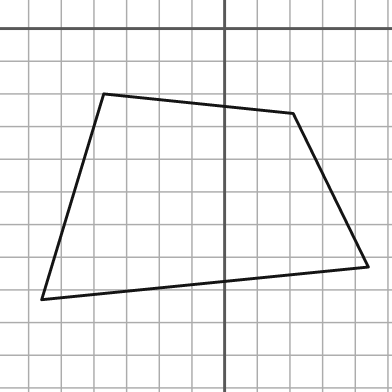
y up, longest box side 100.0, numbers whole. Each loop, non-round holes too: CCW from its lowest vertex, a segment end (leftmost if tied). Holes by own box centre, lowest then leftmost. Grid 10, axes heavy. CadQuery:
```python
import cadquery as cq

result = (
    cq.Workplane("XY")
    .moveTo(-56.0, -83.0)
    .lineTo(44.0, -73.0)
    .lineTo(21.0, -26.0)
    .lineTo(-37.0, -20.0)
    .close()
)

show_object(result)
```